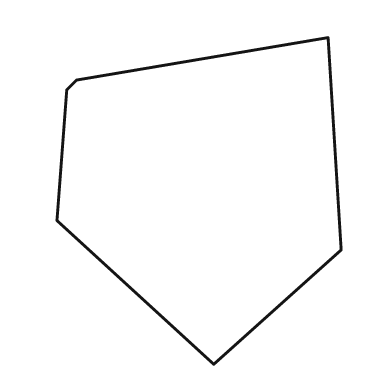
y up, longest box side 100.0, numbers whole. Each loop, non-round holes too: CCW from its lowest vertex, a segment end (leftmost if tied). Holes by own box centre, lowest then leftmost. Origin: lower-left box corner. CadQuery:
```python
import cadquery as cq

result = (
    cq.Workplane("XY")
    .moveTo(48.0, 0.0)
    .lineTo(87.0, 35.0)
    .lineTo(83.0, 100.0)
    .lineTo(6.0, 87.0)
    .lineTo(3.0, 84.0)
    .lineTo(0.0, 44.0)
    .close()
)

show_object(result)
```